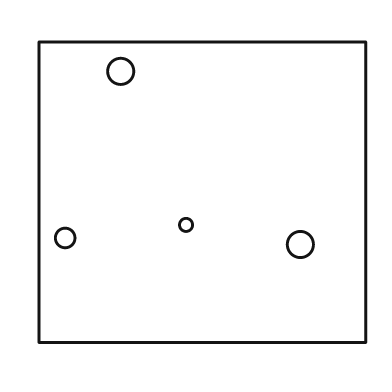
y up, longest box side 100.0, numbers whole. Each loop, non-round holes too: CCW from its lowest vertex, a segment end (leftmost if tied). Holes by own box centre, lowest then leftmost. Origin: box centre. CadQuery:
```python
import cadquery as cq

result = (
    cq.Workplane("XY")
    .moveTo(-50.0, -46.0)
    .lineTo(50.0, -46.0)
    .lineTo(50.0, 46.0)
    .lineTo(-50.0, 46.0)
    .close()
    .moveTo(30.0, -16.0)
    .circle(4.0)
    .moveTo(-42.0, -14.0)
    .circle(3.0)
    .moveTo(-5.0, -10.0)
    .circle(2.0)
    .moveTo(-25.0, 37.0)
    .circle(4.0)
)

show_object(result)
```